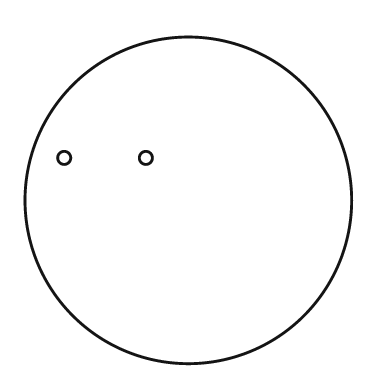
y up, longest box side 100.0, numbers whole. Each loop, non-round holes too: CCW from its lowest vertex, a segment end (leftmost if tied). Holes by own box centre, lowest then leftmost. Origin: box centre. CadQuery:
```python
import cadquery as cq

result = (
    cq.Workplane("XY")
    .moveTo(0.0, 0.0)
    .circle(50.0)
    .moveTo(-38.0, 13.0)
    .circle(2.0)
    .moveTo(-13.0, 13.0)
    .circle(2.0)
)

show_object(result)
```